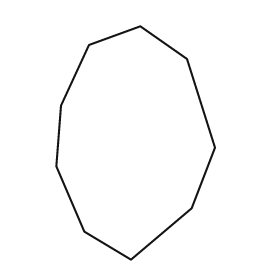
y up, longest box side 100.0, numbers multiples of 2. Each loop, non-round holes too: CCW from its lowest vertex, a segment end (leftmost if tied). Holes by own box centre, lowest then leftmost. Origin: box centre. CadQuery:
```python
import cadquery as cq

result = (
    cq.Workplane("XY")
    .moveTo(-2.0, -50.0)
    .lineTo(24.0, -28.0)
    .lineTo(34.0, -2.0)
    .lineTo(22.0, 36.0)
    .lineTo(2.0, 50.0)
    .lineTo(-20.0, 42.0)
    .lineTo(-32.0, 16.0)
    .lineTo(-34.0, -10.0)
    .lineTo(-22.0, -38.0)
    .close()
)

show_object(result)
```